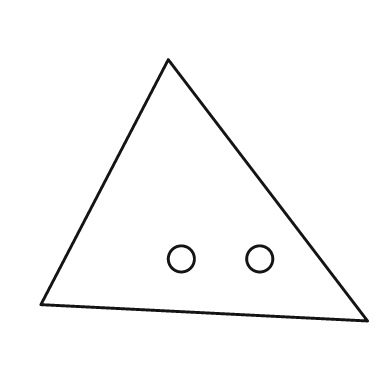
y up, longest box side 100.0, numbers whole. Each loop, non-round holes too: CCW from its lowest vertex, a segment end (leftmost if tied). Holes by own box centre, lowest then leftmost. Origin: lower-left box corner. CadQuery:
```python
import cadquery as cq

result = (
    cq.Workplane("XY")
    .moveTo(100.0, 0.0)
    .lineTo(39.0, 80.0)
    .lineTo(0.0, 5.0)
    .close()
    .moveTo(43.0, 19.0)
    .circle(4.0)
    .moveTo(67.0, 19.0)
    .circle(4.0)
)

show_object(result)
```